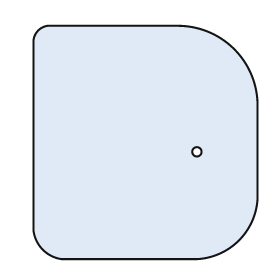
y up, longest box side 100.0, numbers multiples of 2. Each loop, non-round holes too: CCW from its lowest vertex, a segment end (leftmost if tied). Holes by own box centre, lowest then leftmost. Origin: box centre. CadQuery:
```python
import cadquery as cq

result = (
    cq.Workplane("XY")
    .moveTo(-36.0, -50.0)
    .lineTo(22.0, -50.0)
    .threePointArc((40.0, -42.0), (48.0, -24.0))
    .lineTo(48.0, 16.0)
    .threePointArc((38.0, 40.0), (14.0, 50.0))
    .lineTo(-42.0, 50.0)
    .threePointArc((-46.0, 48.0), (-48.0, 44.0))
    .lineTo(-48.0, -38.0)
    .threePointArc((-44.0, -46.0), (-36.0, -50.0))
    .close()
    .moveTo(22.0, -4.0)
    .circle(2.0)
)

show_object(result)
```